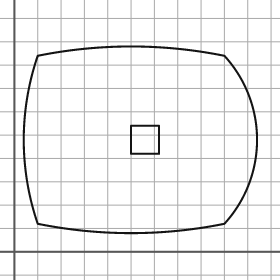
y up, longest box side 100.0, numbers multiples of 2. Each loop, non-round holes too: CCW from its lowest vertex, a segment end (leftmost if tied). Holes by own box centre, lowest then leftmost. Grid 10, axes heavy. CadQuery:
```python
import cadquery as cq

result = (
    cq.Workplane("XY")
    .moveTo(10.0, 12.0)
    .threePointArc((50.0, 8.0), (90.0, 12.0))
    .threePointArc((104.0, 48.0), (90.0, 84.0))
    .threePointArc((50.0, 88.0), (10.0, 84.0))
    .threePointArc((4.0, 48.0), (10.0, 12.0))
    .close()
    .moveTo(50.0, 42.0)
    .lineTo(62.0, 42.0)
    .lineTo(62.0, 54.0)
    .lineTo(50.0, 54.0)
    .close()
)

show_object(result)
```